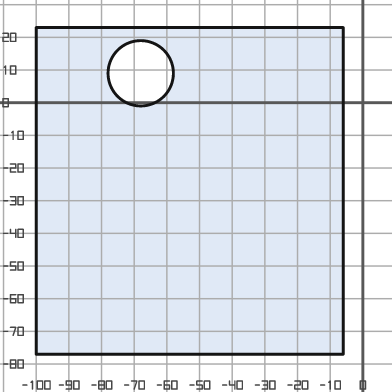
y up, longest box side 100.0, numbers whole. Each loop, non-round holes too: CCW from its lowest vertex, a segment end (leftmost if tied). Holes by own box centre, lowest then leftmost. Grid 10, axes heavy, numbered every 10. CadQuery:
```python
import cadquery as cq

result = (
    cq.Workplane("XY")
    .moveTo(-100.0, -77.0)
    .lineTo(-6.0, -77.0)
    .lineTo(-6.0, 23.0)
    .lineTo(-100.0, 23.0)
    .close()
    .moveTo(-68.0, 9.0)
    .circle(10.0)
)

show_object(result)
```